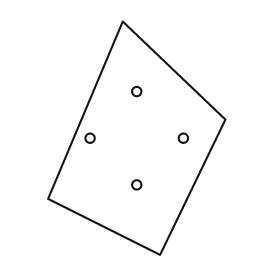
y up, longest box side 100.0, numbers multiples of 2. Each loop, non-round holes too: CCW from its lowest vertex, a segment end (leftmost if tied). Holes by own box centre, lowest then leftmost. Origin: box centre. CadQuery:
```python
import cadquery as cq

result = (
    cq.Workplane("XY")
    .moveTo(10.0, -50.0)
    .lineTo(38.0, 8.0)
    .lineTo(-6.0, 50.0)
    .lineTo(-38.0, -26.0)
    .close()
    .moveTo(0.0, -20.0)
    .circle(2.0)
    .moveTo(-20.0, 0.0)
    .circle(2.0)
    .moveTo(20.0, 0.0)
    .circle(2.0)
    .moveTo(0.0, 20.0)
    .circle(2.0)
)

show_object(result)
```